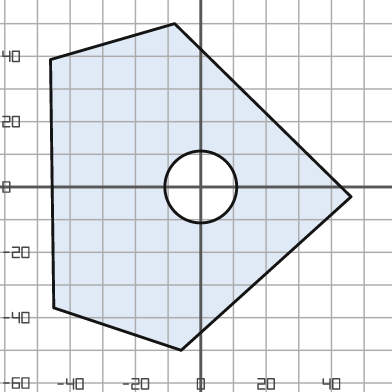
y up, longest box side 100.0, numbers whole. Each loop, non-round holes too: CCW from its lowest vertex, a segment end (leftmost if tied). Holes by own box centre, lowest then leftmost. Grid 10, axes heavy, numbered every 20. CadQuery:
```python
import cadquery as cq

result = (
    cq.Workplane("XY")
    .moveTo(-6.0, -50.0)
    .lineTo(46.0, -3.0)
    .lineTo(-8.0, 50.0)
    .lineTo(-46.0, 39.0)
    .lineTo(-45.0, -37.0)
    .close()
    .moveTo(0.0, 0.0)
    .circle(11.0)
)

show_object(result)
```